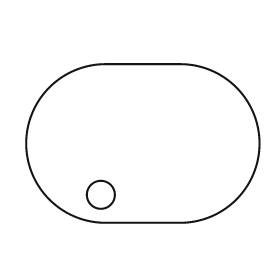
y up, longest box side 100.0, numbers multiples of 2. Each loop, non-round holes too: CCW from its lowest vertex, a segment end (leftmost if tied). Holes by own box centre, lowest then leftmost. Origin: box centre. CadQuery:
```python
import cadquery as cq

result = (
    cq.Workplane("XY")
    .moveTo(-16.0, -34.0)
    .lineTo(16.0, -34.0)
    .threePointArc((50.0, 0.0), (16.0, 34.0))
    .lineTo(-16.0, 34.0)
    .threePointArc((-50.0, 0.0), (-16.0, -34.0))
    .close()
    .moveTo(-18.0, -22.0)
    .circle(6.0)
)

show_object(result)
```